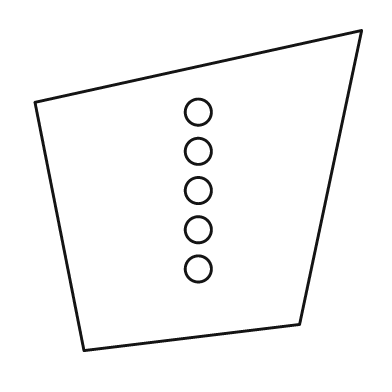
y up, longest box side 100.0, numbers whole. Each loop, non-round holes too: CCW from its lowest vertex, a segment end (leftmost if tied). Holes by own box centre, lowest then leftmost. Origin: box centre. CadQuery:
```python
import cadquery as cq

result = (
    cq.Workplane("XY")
    .moveTo(-35.0, -49.0)
    .lineTo(31.0, -41.0)
    .lineTo(50.0, 49.0)
    .lineTo(-50.0, 27.0)
    .close()
    .moveTo(0.0, -24.0)
    .circle(4.0)
    .moveTo(0.0, -12.0)
    .circle(4.0)
    .moveTo(0.0, 0.0)
    .circle(4.0)
    .moveTo(0.0, 12.0)
    .circle(4.0)
    .moveTo(0.0, 24.0)
    .circle(4.0)
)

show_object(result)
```